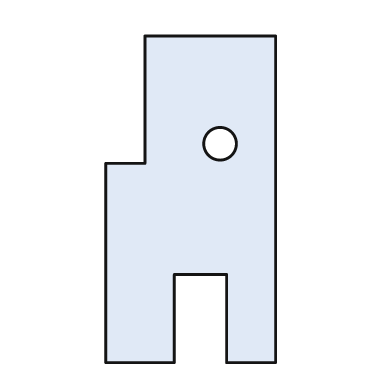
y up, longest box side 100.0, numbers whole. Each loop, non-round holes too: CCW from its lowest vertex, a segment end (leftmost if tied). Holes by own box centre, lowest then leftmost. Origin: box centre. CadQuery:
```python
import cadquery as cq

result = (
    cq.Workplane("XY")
    .moveTo(-26.0, -50.0)
    .lineTo(-5.0, -50.0)
    .lineTo(-5.0, -23.0)
    .lineTo(11.0, -23.0)
    .lineTo(11.0, -50.0)
    .lineTo(26.0, -50.0)
    .lineTo(26.0, 50.0)
    .lineTo(-14.0, 50.0)
    .lineTo(-14.0, 11.0)
    .lineTo(-26.0, 11.0)
    .close()
    .moveTo(9.0, 17.0)
    .circle(5.0)
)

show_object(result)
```